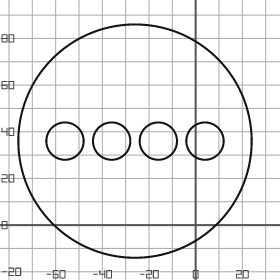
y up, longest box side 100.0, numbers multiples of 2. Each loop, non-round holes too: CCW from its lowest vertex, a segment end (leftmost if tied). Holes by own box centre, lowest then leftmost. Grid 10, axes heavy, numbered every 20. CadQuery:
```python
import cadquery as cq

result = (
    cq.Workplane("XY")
    .moveTo(-26.0, 36.0)
    .circle(50.0)
    .moveTo(-56.0, 36.0)
    .circle(8.0)
    .moveTo(-36.0, 36.0)
    .circle(8.0)
    .moveTo(-16.0, 36.0)
    .circle(8.0)
    .moveTo(4.0, 36.0)
    .circle(8.0)
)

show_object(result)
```